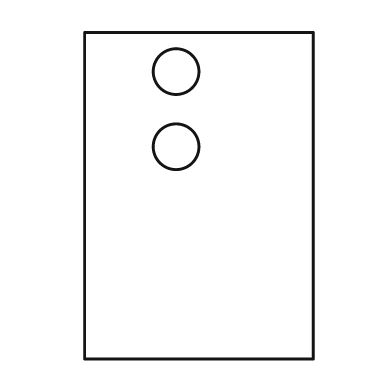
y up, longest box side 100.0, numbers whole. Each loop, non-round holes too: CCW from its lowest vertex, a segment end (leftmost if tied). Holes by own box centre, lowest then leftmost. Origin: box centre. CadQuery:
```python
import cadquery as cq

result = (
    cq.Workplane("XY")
    .moveTo(-35.0, -50.0)
    .lineTo(35.0, -50.0)
    .lineTo(35.0, 50.0)
    .lineTo(-35.0, 50.0)
    .close()
    .moveTo(-7.0, 15.0)
    .circle(7.0)
    .moveTo(-7.0, 38.0)
    .circle(7.0)
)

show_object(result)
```